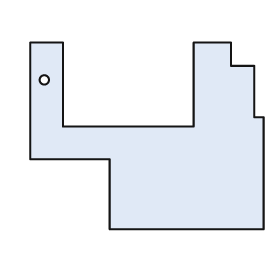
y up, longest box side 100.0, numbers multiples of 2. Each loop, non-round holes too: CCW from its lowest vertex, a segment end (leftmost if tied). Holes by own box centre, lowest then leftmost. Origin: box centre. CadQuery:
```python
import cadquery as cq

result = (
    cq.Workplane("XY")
    .moveTo(-16.0, -40.0)
    .lineTo(50.0, -40.0)
    .lineTo(50.0, 8.0)
    .lineTo(46.0, 8.0)
    .lineTo(46.0, 30.0)
    .lineTo(36.0, 30.0)
    .lineTo(36.0, 40.0)
    .lineTo(20.0, 40.0)
    .lineTo(20.0, 4.0)
    .lineTo(-36.0, 4.0)
    .lineTo(-36.0, 40.0)
    .lineTo(-50.0, 40.0)
    .lineTo(-50.0, -10.0)
    .lineTo(-16.0, -10.0)
    .close()
    .moveTo(-44.0, 24.0)
    .circle(2.0)
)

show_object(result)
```